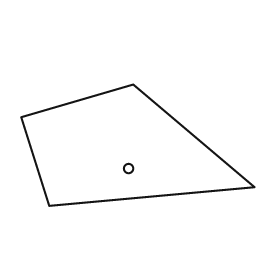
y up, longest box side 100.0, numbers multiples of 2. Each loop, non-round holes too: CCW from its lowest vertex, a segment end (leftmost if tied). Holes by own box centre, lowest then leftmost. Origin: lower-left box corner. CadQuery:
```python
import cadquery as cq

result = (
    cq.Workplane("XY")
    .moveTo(12.0, 0.0)
    .lineTo(100.0, 8.0)
    .lineTo(48.0, 52.0)
    .lineTo(0.0, 38.0)
    .close()
    .moveTo(46.0, 16.0)
    .circle(2.0)
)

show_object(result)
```